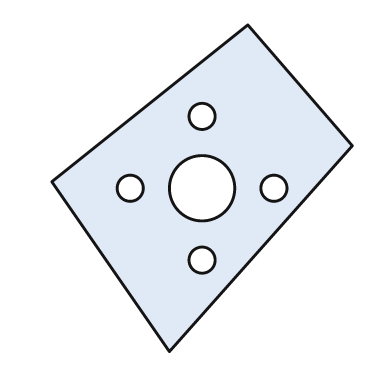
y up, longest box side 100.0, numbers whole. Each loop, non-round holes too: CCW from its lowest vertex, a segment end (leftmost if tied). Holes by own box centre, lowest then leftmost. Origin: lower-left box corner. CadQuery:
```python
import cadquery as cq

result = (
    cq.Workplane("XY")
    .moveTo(36.0, 0.0)
    .lineTo(92.0, 63.0)
    .lineTo(60.0, 100.0)
    .lineTo(0.0, 52.0)
    .close()
    .moveTo(46.0, 28.0)
    .circle(4.0)
    .moveTo(24.0, 50.0)
    .circle(4.0)
    .moveTo(46.0, 50.0)
    .circle(10.0)
    .moveTo(68.0, 50.0)
    .circle(4.0)
    .moveTo(46.0, 72.0)
    .circle(4.0)
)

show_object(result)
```